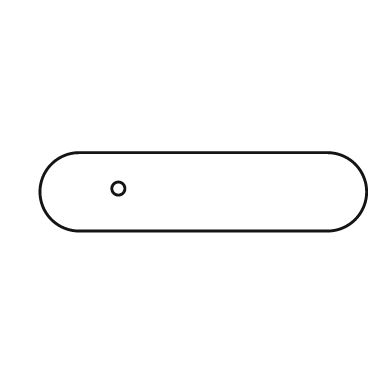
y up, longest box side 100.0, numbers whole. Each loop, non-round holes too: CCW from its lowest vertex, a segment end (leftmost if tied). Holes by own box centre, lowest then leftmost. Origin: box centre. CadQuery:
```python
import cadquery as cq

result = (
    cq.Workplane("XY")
    .moveTo(-38.0, -12.0)
    .lineTo(38.0, -12.0)
    .threePointArc((50.0, 0.0), (38.0, 12.0))
    .lineTo(-38.0, 12.0)
    .threePointArc((-50.0, 0.0), (-38.0, -12.0))
    .close()
    .moveTo(-26.0, 1.0)
    .circle(2.0)
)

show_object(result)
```